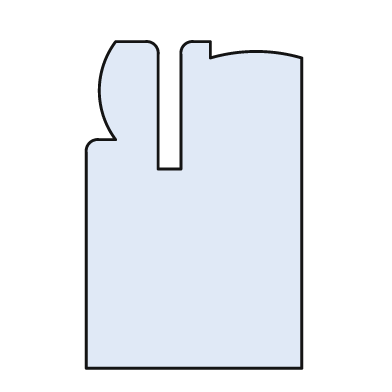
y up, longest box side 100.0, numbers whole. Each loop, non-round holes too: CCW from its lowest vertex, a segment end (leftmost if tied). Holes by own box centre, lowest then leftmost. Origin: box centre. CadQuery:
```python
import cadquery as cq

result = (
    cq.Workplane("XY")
    .moveTo(-33.0, -50.0)
    .lineTo(33.0, -50.0)
    .lineTo(33.0, 45.0)
    .threePointArc((19.0, 47.0), (5.0, 45.0))
    .lineTo(5.0, 50.0)
    .lineTo(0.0, 50.0)
    .threePointArc((-3.0, 49.0), (-4.0, 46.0))
    .lineTo(-4.0, 11.0)
    .lineTo(-11.0, 11.0)
    .lineTo(-11.0, 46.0)
    .threePointArc((-12.0, 49.0), (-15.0, 50.0))
    .lineTo(-24.0, 50.0)
    .threePointArc((-29.0, 35.0), (-24.0, 20.0))
    .lineTo(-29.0, 20.0)
    .threePointArc((-32.0, 19.0), (-33.0, 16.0))
    .close()
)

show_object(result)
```